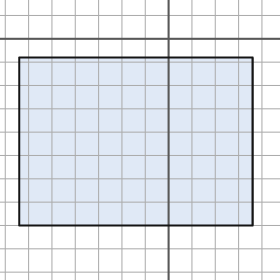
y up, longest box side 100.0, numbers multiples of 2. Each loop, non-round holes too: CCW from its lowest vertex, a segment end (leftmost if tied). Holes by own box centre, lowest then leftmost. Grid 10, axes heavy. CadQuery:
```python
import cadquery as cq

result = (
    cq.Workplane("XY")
    .moveTo(-64.0, -80.0)
    .lineTo(36.0, -80.0)
    .lineTo(36.0, -8.0)
    .lineTo(-64.0, -8.0)
    .close()
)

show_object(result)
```